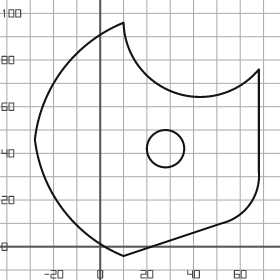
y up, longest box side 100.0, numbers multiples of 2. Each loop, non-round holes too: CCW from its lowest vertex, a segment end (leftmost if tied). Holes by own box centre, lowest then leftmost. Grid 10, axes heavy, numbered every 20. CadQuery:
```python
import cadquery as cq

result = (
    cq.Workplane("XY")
    .moveTo(10.0, -4.0)
    .lineTo(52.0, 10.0)
    .threePointArc((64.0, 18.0), (68.0, 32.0))
    .lineTo(68.0, 76.0)
    .threePointArc((32.0, 66.0), (10.0, 96.0))
    .threePointArc((-16.0, 76.0), (-28.0, 46.0))
    .threePointArc((-16.0, 16.0), (10.0, -4.0))
    .close()
    .moveTo(28.0, 42.0)
    .circle(8.0)
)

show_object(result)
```